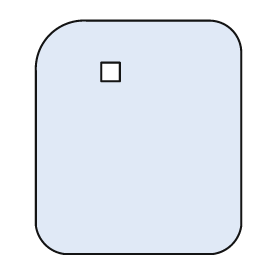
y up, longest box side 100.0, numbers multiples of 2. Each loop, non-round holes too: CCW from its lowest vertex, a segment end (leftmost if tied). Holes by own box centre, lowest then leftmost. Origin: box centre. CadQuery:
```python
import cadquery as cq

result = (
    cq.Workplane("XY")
    .moveTo(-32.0, -50.0)
    .lineTo(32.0, -50.0)
    .threePointArc((40.0, -46.0), (44.0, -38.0))
    .lineTo(44.0, 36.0)
    .threePointArc((40.0, 46.0), (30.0, 50.0))
    .lineTo(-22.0, 50.0)
    .threePointArc((-38.0, 44.0), (-44.0, 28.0))
    .lineTo(-44.0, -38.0)
    .threePointArc((-40.0, -46.0), (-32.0, -50.0))
    .close()
    .moveTo(-16.0, 24.0)
    .lineTo(-8.0, 24.0)
    .lineTo(-8.0, 32.0)
    .lineTo(-16.0, 32.0)
    .close()
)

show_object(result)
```